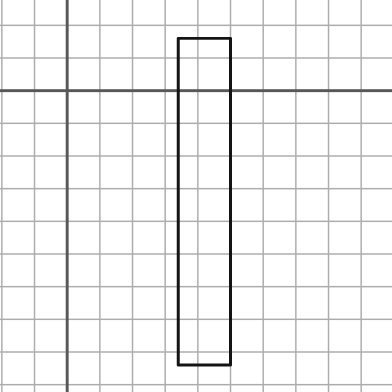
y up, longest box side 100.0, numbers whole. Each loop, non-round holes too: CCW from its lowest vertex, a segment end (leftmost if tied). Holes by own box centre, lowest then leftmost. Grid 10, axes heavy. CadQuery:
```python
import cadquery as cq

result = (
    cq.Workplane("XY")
    .moveTo(34.0, -84.0)
    .lineTo(50.0, -84.0)
    .lineTo(50.0, 16.0)
    .lineTo(34.0, 16.0)
    .close()
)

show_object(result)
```